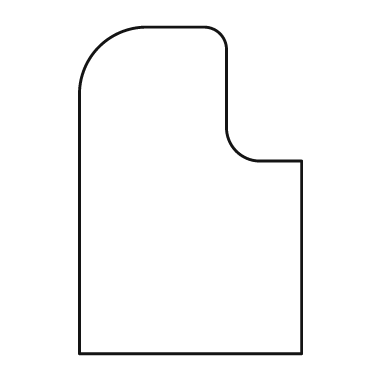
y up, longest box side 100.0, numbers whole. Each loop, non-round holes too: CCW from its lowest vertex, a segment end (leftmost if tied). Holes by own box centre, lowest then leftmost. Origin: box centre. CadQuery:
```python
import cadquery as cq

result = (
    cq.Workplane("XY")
    .moveTo(-34.0, -50.0)
    .lineTo(34.0, -50.0)
    .lineTo(34.0, 9.0)
    .lineTo(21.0, 9.0)
    .threePointArc((14.0, 12.0), (11.0, 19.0))
    .lineTo(11.0, 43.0)
    .threePointArc((9.0, 48.0), (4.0, 50.0))
    .lineTo(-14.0, 50.0)
    .threePointArc((-28.0, 44.0), (-34.0, 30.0))
    .close()
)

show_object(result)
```